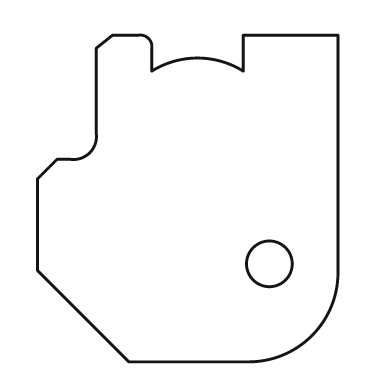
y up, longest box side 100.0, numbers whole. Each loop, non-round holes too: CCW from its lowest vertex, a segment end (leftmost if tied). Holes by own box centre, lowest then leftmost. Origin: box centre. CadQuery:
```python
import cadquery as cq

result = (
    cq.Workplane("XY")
    .moveTo(-18.0, -50.0)
    .lineTo(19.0, -50.0)
    .threePointArc((38.0, -42.0), (46.0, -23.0))
    .lineTo(46.0, 50.0)
    .lineTo(17.0, 50.0)
    .lineTo(17.0, 39.0)
    .threePointArc((3.0, 43.0), (-11.0, 39.0))
    .lineTo(-11.0, 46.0)
    .threePointArc((-12.0, 49.0), (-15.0, 50.0))
    .lineTo(-23.0, 50.0)
    .lineTo(-28.0, 46.0)
    .lineTo(-28.0, 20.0)
    .threePointArc((-30.0, 14.0), (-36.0, 12.0))
    .lineTo(-40.0, 12.0)
    .lineTo(-46.0, 6.0)
    .lineTo(-46.0, -22.0)
    .close()
    .moveTo(25.0, -20.0)
    .circle(7.0)
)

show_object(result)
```